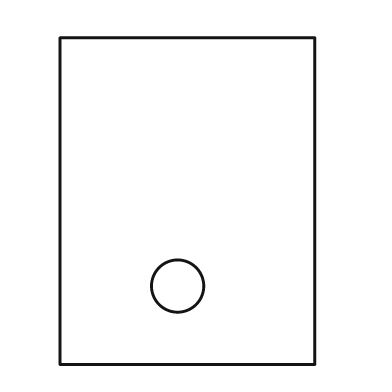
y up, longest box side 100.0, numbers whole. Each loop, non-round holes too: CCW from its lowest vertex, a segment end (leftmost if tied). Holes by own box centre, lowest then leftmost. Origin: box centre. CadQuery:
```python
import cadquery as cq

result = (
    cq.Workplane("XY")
    .moveTo(-39.0, -50.0)
    .lineTo(39.0, -50.0)
    .lineTo(39.0, 50.0)
    .lineTo(-39.0, 50.0)
    .close()
    .moveTo(-3.0, -26.0)
    .circle(8.0)
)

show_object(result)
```